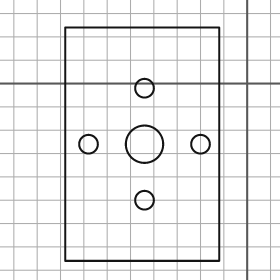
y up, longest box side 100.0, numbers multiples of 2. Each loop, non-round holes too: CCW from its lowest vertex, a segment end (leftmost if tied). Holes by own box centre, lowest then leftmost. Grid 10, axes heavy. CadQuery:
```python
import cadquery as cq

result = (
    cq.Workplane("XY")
    .moveTo(-78.0, -76.0)
    .lineTo(-12.0, -76.0)
    .lineTo(-12.0, 24.0)
    .lineTo(-78.0, 24.0)
    .close()
    .moveTo(-44.0, -50.0)
    .circle(4.0)
    .moveTo(-68.0, -26.0)
    .circle(4.0)
    .moveTo(-44.0, -26.0)
    .circle(8.0)
    .moveTo(-20.0, -26.0)
    .circle(4.0)
    .moveTo(-44.0, -2.0)
    .circle(4.0)
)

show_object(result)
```